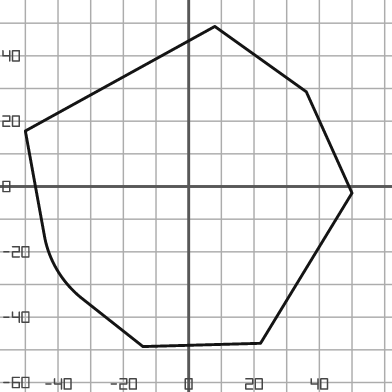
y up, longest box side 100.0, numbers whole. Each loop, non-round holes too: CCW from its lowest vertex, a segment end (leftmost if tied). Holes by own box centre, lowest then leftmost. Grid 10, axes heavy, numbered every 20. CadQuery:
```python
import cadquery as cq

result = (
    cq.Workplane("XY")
    .moveTo(-14.0, -49.0)
    .lineTo(22.0, -48.0)
    .lineTo(50.0, -2.0)
    .lineTo(36.0, 29.0)
    .lineTo(8.0, 49.0)
    .lineTo(-50.0, 17.0)
    .lineTo(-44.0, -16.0)
    .threePointArc((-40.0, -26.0), (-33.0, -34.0))
    .close()
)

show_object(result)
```